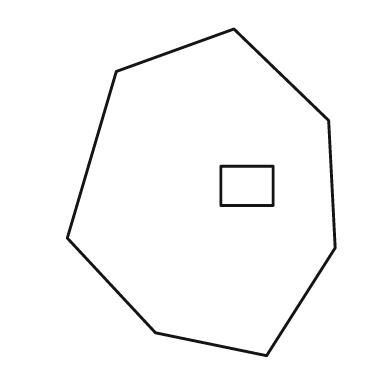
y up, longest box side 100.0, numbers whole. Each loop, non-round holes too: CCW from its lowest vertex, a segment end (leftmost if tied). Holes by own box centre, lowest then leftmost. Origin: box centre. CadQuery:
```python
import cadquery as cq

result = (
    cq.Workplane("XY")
    .moveTo(20.0, -50.0)
    .lineTo(41.0, -17.0)
    .lineTo(39.0, 22.0)
    .lineTo(10.0, 50.0)
    .lineTo(-26.0, 37.0)
    .lineTo(-41.0, -14.0)
    .lineTo(-14.0, -43.0)
    .close()
    .moveTo(6.0, -4.0)
    .lineTo(22.0, -4.0)
    .lineTo(22.0, 8.0)
    .lineTo(6.0, 8.0)
    .close()
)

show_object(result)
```